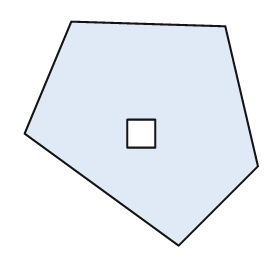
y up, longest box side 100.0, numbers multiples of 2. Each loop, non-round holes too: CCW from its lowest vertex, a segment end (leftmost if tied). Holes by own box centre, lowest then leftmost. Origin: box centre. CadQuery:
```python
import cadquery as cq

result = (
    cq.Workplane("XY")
    .moveTo(16.0, -48.0)
    .lineTo(50.0, -14.0)
    .lineTo(36.0, 46.0)
    .lineTo(-30.0, 48.0)
    .lineTo(-50.0, 0.0)
    .close()
    .moveTo(-6.0, -6.0)
    .lineTo(6.0, -6.0)
    .lineTo(6.0, 6.0)
    .lineTo(-6.0, 6.0)
    .close()
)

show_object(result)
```